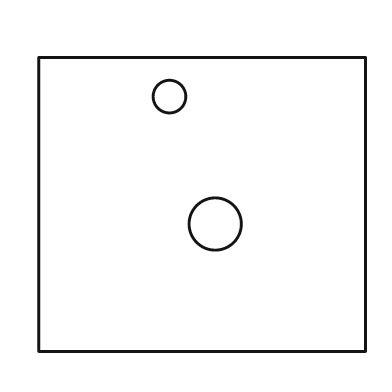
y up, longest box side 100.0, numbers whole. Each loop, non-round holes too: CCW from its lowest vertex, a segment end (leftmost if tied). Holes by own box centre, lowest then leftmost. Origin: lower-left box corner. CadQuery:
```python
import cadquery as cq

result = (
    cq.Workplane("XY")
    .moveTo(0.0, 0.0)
    .lineTo(100.0, 0.0)
    .lineTo(100.0, 90.0)
    .lineTo(0.0, 90.0)
    .close()
    .moveTo(54.0, 39.0)
    .circle(8.0)
    .moveTo(40.0, 78.0)
    .circle(5.0)
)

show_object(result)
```